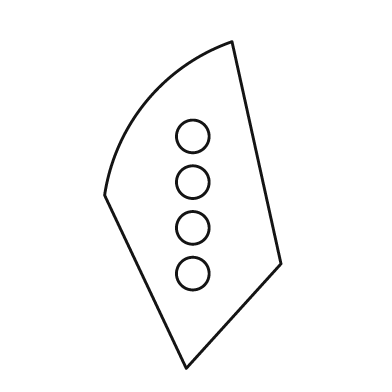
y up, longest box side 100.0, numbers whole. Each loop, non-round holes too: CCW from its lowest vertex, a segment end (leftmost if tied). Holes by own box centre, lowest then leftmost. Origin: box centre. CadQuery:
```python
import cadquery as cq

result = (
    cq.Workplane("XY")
    .moveTo(-2.0, -50.0)
    .lineTo(27.0, -18.0)
    .lineTo(12.0, 50.0)
    .threePointArc((-14.0, 32.0), (-27.0, 3.0))
    .close()
    .moveTo(0.0, -21.0)
    .circle(5.0)
    .moveTo(0.0, -7.0)
    .circle(5.0)
    .moveTo(0.0, 7.0)
    .circle(5.0)
    .moveTo(0.0, 21.0)
    .circle(5.0)
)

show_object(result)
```